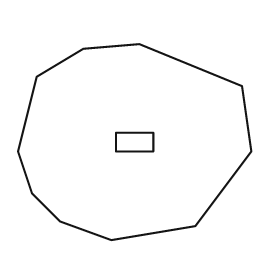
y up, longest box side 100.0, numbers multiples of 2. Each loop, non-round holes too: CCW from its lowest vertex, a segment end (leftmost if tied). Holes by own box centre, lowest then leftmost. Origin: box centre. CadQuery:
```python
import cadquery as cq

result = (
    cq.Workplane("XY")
    .moveTo(-10.0, -42.0)
    .lineTo(26.0, -36.0)
    .lineTo(50.0, -4.0)
    .lineTo(46.0, 24.0)
    .lineTo(2.0, 42.0)
    .lineTo(-22.0, 40.0)
    .lineTo(-42.0, 28.0)
    .lineTo(-50.0, -4.0)
    .lineTo(-44.0, -22.0)
    .lineTo(-32.0, -34.0)
    .close()
    .moveTo(-8.0, -4.0)
    .lineTo(8.0, -4.0)
    .lineTo(8.0, 4.0)
    .lineTo(-8.0, 4.0)
    .close()
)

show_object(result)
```